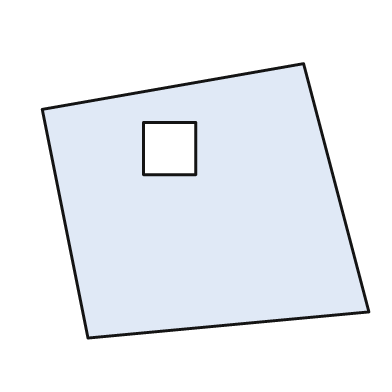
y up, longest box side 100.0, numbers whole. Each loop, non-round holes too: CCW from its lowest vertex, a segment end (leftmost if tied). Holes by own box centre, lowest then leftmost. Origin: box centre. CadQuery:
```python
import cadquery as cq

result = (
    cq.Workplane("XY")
    .moveTo(-36.0, -42.0)
    .lineTo(50.0, -34.0)
    .lineTo(30.0, 42.0)
    .lineTo(-50.0, 28.0)
    .close()
    .moveTo(-19.0, 8.0)
    .lineTo(-3.0, 8.0)
    .lineTo(-3.0, 24.0)
    .lineTo(-19.0, 24.0)
    .close()
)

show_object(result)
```